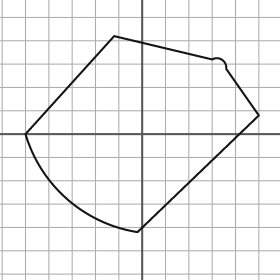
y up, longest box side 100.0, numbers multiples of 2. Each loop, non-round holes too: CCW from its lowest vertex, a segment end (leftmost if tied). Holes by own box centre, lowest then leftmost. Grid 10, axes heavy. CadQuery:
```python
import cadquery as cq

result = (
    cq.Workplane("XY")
    .moveTo(-2.0, -42.0)
    .lineTo(50.0, 8.0)
    .lineTo(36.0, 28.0)
    .threePointArc((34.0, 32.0), (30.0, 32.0))
    .lineTo(-12.0, 42.0)
    .lineTo(-50.0, 0.0)
    .threePointArc((-32.0, -28.0), (-2.0, -42.0))
    .close()
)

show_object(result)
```